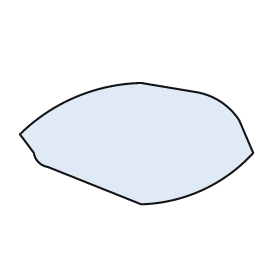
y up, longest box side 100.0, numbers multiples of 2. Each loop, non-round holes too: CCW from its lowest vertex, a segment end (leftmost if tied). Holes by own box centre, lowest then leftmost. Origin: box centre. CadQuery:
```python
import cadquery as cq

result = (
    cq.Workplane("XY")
    .moveTo(2.0, -26.0)
    .threePointArc((28.0, -20.0), (50.0, -4.0))
    .lineTo(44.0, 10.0)
    .threePointArc((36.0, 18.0), (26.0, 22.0))
    .lineTo(2.0, 26.0)
    .threePointArc((-26.0, 20.0), (-50.0, 4.0))
    .lineTo(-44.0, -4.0)
    .threePointArc((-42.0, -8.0), (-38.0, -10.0))
    .close()
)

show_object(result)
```